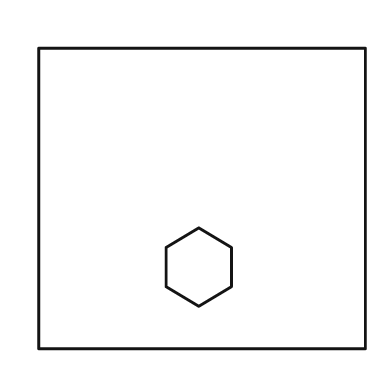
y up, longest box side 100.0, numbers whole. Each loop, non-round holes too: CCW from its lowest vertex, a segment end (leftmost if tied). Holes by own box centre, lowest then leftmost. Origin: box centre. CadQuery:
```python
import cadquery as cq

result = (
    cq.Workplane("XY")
    .moveTo(-50.0, -46.0)
    .lineTo(50.0, -46.0)
    .lineTo(50.0, 46.0)
    .lineTo(-50.0, 46.0)
    .close()
    .moveTo(-1.0, -33.0)
    .lineTo(9.0, -27.0)
    .lineTo(9.0, -15.0)
    .lineTo(-1.0, -9.0)
    .lineTo(-11.0, -15.0)
    .lineTo(-11.0, -27.0)
    .close()
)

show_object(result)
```